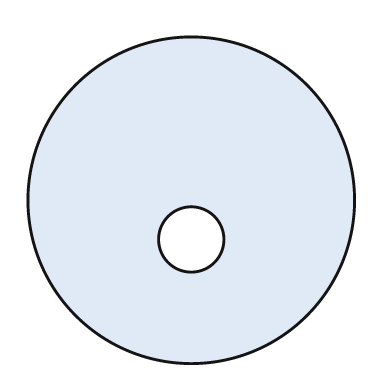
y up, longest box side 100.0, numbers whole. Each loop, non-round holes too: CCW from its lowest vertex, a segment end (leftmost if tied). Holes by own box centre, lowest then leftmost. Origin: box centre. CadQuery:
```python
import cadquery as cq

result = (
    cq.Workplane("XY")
    .moveTo(0.0, 0.0)
    .circle(50.0)
    .moveTo(0.0, -12.0)
    .circle(10.0)
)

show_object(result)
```